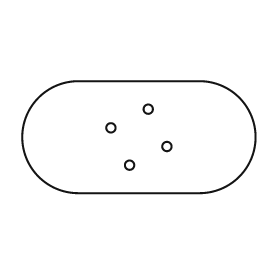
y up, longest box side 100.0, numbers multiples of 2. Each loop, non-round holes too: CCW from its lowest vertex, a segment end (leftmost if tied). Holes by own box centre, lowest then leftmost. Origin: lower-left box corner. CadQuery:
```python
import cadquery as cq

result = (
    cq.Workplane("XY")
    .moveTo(24.0, 0.0)
    .lineTo(76.0, 0.0)
    .threePointArc((100.0, 24.0), (76.0, 48.0))
    .lineTo(24.0, 48.0)
    .threePointArc((0.0, 24.0), (24.0, 0.0))
    .close()
    .moveTo(46.0, 12.0)
    .circle(2.0)
    .moveTo(62.0, 20.0)
    .circle(2.0)
    .moveTo(38.0, 28.0)
    .circle(2.0)
    .moveTo(54.0, 36.0)
    .circle(2.0)
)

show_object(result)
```